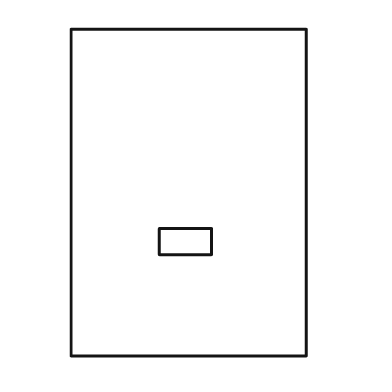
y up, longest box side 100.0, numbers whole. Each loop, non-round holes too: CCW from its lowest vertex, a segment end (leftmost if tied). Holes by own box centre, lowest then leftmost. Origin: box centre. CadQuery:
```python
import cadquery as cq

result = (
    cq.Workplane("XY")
    .moveTo(-36.0, -50.0)
    .lineTo(36.0, -50.0)
    .lineTo(36.0, 50.0)
    .lineTo(-36.0, 50.0)
    .close()
    .moveTo(-9.0, -19.0)
    .lineTo(7.0, -19.0)
    .lineTo(7.0, -11.0)
    .lineTo(-9.0, -11.0)
    .close()
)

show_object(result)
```